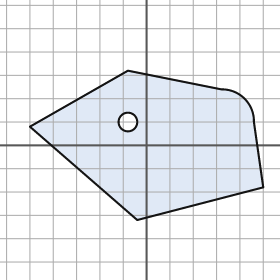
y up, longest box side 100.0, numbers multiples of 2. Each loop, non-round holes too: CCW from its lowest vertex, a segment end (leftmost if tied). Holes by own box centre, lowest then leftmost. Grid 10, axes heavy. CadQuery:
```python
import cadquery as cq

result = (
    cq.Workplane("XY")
    .moveTo(-4.0, -32.0)
    .lineTo(50.0, -18.0)
    .lineTo(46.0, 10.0)
    .threePointArc((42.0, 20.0), (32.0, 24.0))
    .lineTo(-8.0, 32.0)
    .lineTo(-50.0, 8.0)
    .close()
    .moveTo(-8.0, 10.0)
    .circle(4.0)
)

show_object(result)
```